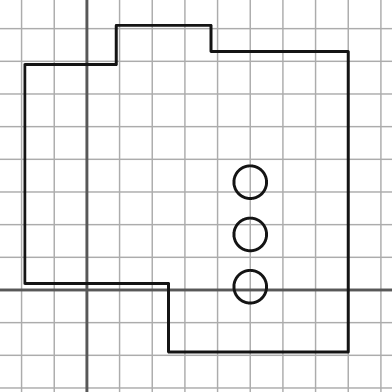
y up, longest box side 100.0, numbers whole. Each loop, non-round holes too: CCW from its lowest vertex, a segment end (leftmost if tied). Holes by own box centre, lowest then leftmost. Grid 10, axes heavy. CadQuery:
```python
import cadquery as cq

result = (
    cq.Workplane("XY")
    .moveTo(25.0, -19.0)
    .lineTo(80.0, -19.0)
    .lineTo(80.0, 73.0)
    .lineTo(38.0, 73.0)
    .lineTo(38.0, 81.0)
    .lineTo(9.0, 81.0)
    .lineTo(9.0, 69.0)
    .lineTo(-19.0, 69.0)
    .lineTo(-19.0, 2.0)
    .lineTo(25.0, 2.0)
    .close()
    .moveTo(50.0, 1.0)
    .circle(5.0)
    .moveTo(50.0, 17.0)
    .circle(5.0)
    .moveTo(50.0, 33.0)
    .circle(5.0)
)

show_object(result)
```